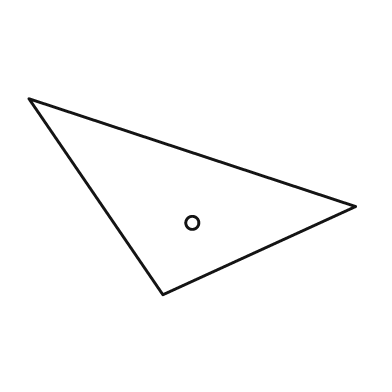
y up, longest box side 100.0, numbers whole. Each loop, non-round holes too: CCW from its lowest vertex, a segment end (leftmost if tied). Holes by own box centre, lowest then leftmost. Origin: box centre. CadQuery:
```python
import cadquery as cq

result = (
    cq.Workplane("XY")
    .moveTo(-9.0, -30.0)
    .lineTo(50.0, -3.0)
    .lineTo(-50.0, 30.0)
    .close()
    .moveTo(0.0, -8.0)
    .circle(2.0)
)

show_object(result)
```